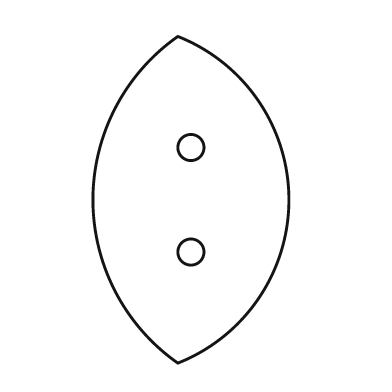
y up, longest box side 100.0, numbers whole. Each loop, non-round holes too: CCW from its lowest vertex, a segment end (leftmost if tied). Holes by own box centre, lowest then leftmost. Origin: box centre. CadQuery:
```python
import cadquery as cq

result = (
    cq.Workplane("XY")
    .moveTo(-4.0, -50.0)
    .threePointArc((30.0, 0.0), (-4.0, 50.0))
    .threePointArc((-30.0, 0.0), (-4.0, -50.0))
    .close()
    .moveTo(0.0, -16.0)
    .circle(4.0)
    .moveTo(0.0, 16.0)
    .circle(4.0)
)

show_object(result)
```